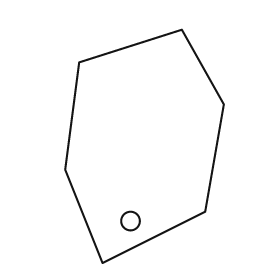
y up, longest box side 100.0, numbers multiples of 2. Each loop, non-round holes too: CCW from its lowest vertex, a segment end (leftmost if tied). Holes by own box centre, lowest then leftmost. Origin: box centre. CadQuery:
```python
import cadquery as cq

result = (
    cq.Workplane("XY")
    .moveTo(-18.0, -50.0)
    .lineTo(26.0, -28.0)
    .lineTo(34.0, 18.0)
    .lineTo(16.0, 50.0)
    .lineTo(-28.0, 36.0)
    .lineTo(-34.0, -10.0)
    .close()
    .moveTo(-6.0, -32.0)
    .circle(4.0)
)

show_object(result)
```